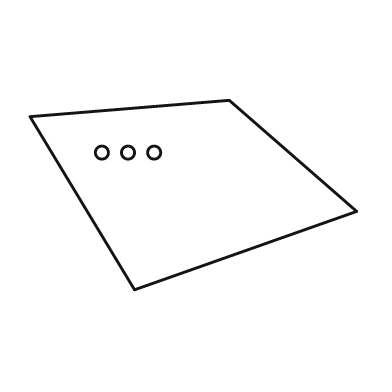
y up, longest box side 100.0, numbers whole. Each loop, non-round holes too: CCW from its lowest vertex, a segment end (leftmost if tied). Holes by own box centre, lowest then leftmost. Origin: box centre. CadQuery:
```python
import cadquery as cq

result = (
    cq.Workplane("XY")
    .moveTo(-18.0, -29.0)
    .lineTo(50.0, -5.0)
    .lineTo(11.0, 29.0)
    .lineTo(-50.0, 24.0)
    .close()
    .moveTo(-28.0, 13.0)
    .circle(2.0)
    .moveTo(-20.0, 13.0)
    .circle(2.0)
    .moveTo(-12.0, 13.0)
    .circle(2.0)
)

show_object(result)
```